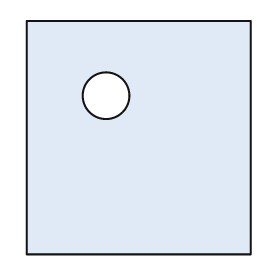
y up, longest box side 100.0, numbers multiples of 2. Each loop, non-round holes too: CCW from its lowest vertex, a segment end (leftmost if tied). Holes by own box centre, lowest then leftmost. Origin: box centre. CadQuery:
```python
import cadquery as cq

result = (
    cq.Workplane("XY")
    .moveTo(-48.0, -50.0)
    .lineTo(48.0, -50.0)
    .lineTo(48.0, 50.0)
    .lineTo(-48.0, 50.0)
    .close()
    .moveTo(-14.0, 18.0)
    .circle(10.0)
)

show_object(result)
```